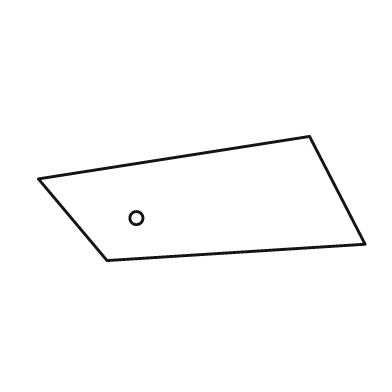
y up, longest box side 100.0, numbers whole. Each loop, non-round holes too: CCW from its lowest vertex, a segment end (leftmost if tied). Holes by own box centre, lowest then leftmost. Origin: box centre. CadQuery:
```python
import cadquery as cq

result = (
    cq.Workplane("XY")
    .moveTo(-29.0, -19.0)
    .lineTo(50.0, -14.0)
    .lineTo(33.0, 19.0)
    .lineTo(-50.0, 6.0)
    .close()
    .moveTo(-20.0, -6.0)
    .circle(2.0)
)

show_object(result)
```